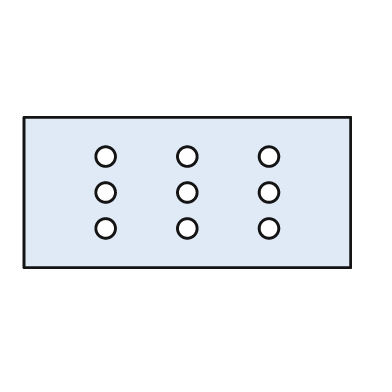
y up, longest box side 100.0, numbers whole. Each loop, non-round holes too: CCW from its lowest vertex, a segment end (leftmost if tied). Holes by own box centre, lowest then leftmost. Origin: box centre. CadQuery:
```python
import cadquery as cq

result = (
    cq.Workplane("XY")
    .moveTo(-50.0, -23.0)
    .lineTo(50.0, -23.0)
    .lineTo(50.0, 23.0)
    .lineTo(-50.0, 23.0)
    .close()
    .moveTo(-25.0, -11.0)
    .circle(3.0)
    .moveTo(0.0, -11.0)
    .circle(3.0)
    .moveTo(25.0, -11.0)
    .circle(3.0)
    .moveTo(-25.0, 0.0)
    .circle(3.0)
    .moveTo(0.0, 0.0)
    .circle(3.0)
    .moveTo(25.0, 0.0)
    .circle(3.0)
    .moveTo(-25.0, 11.0)
    .circle(3.0)
    .moveTo(0.0, 11.0)
    .circle(3.0)
    .moveTo(25.0, 11.0)
    .circle(3.0)
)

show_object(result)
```